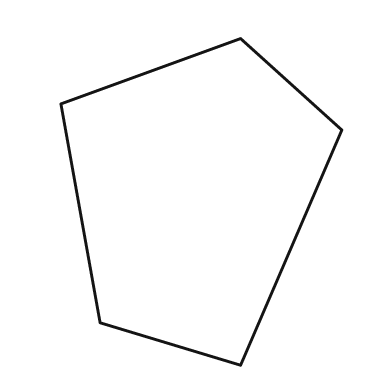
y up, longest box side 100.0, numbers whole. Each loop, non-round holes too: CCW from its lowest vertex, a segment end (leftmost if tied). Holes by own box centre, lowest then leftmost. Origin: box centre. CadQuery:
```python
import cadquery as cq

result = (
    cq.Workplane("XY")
    .moveTo(12.0, -50.0)
    .lineTo(43.0, 22.0)
    .lineTo(12.0, 50.0)
    .lineTo(-43.0, 30.0)
    .lineTo(-31.0, -37.0)
    .close()
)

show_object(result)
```